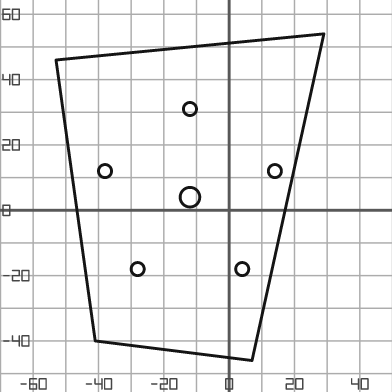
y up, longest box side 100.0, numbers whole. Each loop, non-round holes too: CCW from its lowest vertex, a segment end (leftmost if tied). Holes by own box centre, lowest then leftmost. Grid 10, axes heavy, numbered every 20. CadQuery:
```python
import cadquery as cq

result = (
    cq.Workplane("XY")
    .moveTo(7.0, -46.0)
    .lineTo(29.0, 54.0)
    .lineTo(-53.0, 46.0)
    .lineTo(-41.0, -40.0)
    .close()
    .moveTo(-28.0, -18.0)
    .circle(2.0)
    .moveTo(4.0, -18.0)
    .circle(2.0)
    .moveTo(-12.0, 4.0)
    .circle(3.0)
    .moveTo(-38.0, 12.0)
    .circle(2.0)
    .moveTo(14.0, 12.0)
    .circle(2.0)
    .moveTo(-12.0, 31.0)
    .circle(2.0)
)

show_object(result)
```